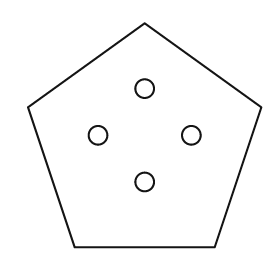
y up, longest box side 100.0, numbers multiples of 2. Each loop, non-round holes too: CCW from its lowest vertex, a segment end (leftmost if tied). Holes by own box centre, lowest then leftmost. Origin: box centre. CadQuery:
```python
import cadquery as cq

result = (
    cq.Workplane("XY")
    .moveTo(-30.0, -48.0)
    .lineTo(30.0, -48.0)
    .lineTo(50.0, 12.0)
    .lineTo(0.0, 48.0)
    .lineTo(-50.0, 12.0)
    .close()
    .moveTo(0.0, -20.0)
    .circle(4.0)
    .moveTo(-20.0, 0.0)
    .circle(4.0)
    .moveTo(20.0, 0.0)
    .circle(4.0)
    .moveTo(0.0, 20.0)
    .circle(4.0)
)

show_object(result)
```